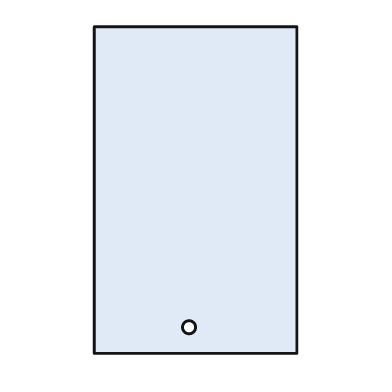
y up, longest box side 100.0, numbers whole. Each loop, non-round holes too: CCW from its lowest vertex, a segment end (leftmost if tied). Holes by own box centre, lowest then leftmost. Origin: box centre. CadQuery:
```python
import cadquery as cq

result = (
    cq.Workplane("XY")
    .moveTo(-31.0, -50.0)
    .lineTo(31.0, -50.0)
    .lineTo(31.0, 50.0)
    .lineTo(-31.0, 50.0)
    .close()
    .moveTo(-2.0, -42.0)
    .circle(2.0)
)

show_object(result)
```